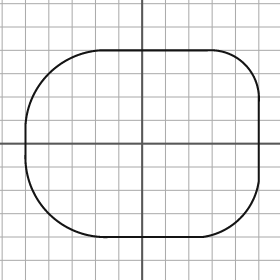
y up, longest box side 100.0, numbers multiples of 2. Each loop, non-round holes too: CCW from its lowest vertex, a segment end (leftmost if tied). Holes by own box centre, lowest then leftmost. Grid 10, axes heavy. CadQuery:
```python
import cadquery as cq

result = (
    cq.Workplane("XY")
    .moveTo(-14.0, -40.0)
    .lineTo(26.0, -40.0)
    .threePointArc((42.0, -32.0), (50.0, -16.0))
    .lineTo(50.0, 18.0)
    .threePointArc((44.0, 34.0), (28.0, 40.0))
    .lineTo(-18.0, 40.0)
    .threePointArc((-40.0, 30.0), (-50.0, 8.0))
    .lineTo(-50.0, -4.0)
    .threePointArc((-40.0, -30.0), (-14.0, -40.0))
    .close()
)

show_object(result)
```